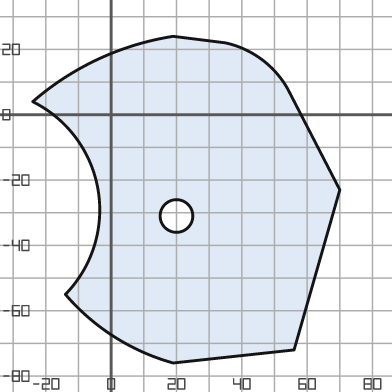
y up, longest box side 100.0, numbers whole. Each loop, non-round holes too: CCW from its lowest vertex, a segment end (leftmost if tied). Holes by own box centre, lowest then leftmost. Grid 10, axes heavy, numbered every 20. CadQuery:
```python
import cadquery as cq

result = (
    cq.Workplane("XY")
    .moveTo(19.0, -76.0)
    .lineTo(56.0, -72.0)
    .lineTo(70.0, -23.0)
    .lineTo(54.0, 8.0)
    .threePointArc((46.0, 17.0), (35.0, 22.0))
    .lineTo(19.0, 24.0)
    .threePointArc((-4.0, 17.0), (-24.0, 4.0))
    .threePointArc((-4.0, -23.0), (-14.0, -55.0))
    .threePointArc((1.0, -68.0), (19.0, -76.0))
    .close()
    .moveTo(20.0, -31.0)
    .circle(5.0)
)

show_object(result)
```